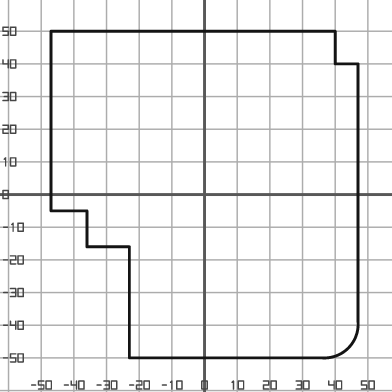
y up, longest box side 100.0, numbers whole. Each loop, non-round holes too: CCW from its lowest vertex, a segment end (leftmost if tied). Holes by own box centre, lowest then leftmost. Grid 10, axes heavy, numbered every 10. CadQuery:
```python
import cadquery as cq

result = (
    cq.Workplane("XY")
    .moveTo(-23.0, -50.0)
    .lineTo(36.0, -50.0)
    .threePointArc((44.0, -47.0), (47.0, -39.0))
    .lineTo(47.0, 40.0)
    .lineTo(40.0, 40.0)
    .lineTo(40.0, 50.0)
    .lineTo(-47.0, 50.0)
    .lineTo(-47.0, -5.0)
    .lineTo(-36.0, -5.0)
    .lineTo(-36.0, -16.0)
    .lineTo(-23.0, -16.0)
    .close()
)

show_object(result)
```